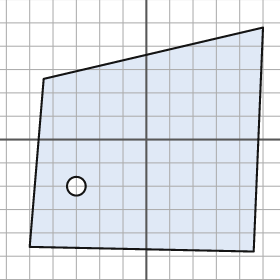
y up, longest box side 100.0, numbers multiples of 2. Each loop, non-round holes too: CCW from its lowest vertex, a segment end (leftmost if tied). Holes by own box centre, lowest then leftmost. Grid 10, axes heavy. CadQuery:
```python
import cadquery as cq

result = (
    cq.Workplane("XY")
    .moveTo(46.0, -48.0)
    .lineTo(50.0, 48.0)
    .lineTo(-44.0, 26.0)
    .lineTo(-50.0, -46.0)
    .close()
    .moveTo(-30.0, -20.0)
    .circle(4.0)
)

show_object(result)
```